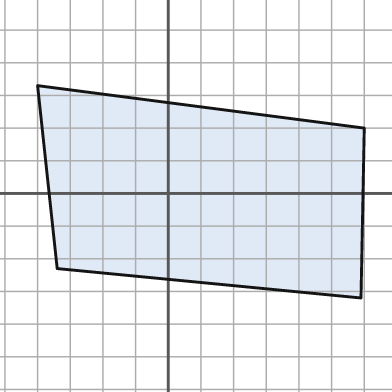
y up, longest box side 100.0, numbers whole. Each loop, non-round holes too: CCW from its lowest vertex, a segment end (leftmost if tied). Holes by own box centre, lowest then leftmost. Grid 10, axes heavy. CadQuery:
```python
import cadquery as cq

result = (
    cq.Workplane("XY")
    .moveTo(59.0, -32.0)
    .lineTo(60.0, 20.0)
    .lineTo(-40.0, 33.0)
    .lineTo(-34.0, -23.0)
    .close()
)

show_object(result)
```